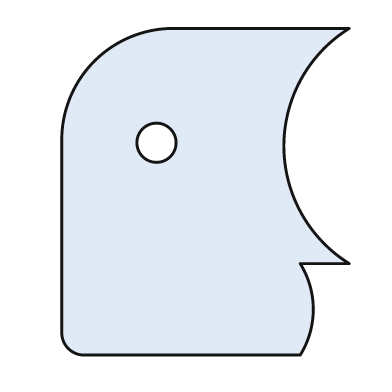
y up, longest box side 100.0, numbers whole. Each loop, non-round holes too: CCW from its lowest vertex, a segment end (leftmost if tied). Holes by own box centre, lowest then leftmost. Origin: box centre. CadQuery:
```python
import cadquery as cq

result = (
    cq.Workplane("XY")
    .moveTo(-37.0, -50.0)
    .lineTo(29.0, -50.0)
    .threePointArc((33.0, -36.0), (29.0, -22.0))
    .lineTo(44.0, -22.0)
    .threePointArc((24.0, 14.0), (44.0, 50.0))
    .lineTo(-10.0, 50.0)
    .threePointArc((-34.0, 40.0), (-44.0, 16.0))
    .lineTo(-44.0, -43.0)
    .threePointArc((-42.0, -48.0), (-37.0, -50.0))
    .close()
    .moveTo(-15.0, 15.0)
    .circle(6.0)
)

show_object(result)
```